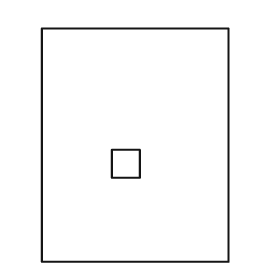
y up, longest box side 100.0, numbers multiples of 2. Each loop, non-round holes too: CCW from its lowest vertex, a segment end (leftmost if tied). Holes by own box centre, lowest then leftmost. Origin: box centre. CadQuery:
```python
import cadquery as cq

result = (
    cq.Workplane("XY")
    .moveTo(-40.0, -50.0)
    .lineTo(40.0, -50.0)
    .lineTo(40.0, 50.0)
    .lineTo(-40.0, 50.0)
    .close()
    .moveTo(-10.0, -14.0)
    .lineTo(2.0, -14.0)
    .lineTo(2.0, -2.0)
    .lineTo(-10.0, -2.0)
    .close()
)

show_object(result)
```